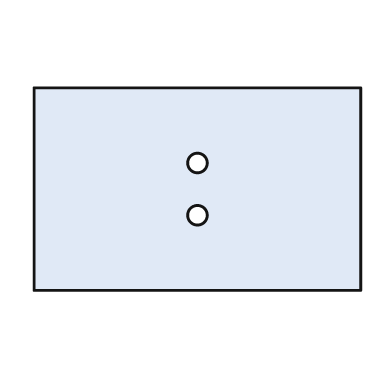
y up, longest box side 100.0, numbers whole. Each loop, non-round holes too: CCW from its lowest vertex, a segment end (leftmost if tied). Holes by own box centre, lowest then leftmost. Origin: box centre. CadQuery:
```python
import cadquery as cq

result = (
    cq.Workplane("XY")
    .moveTo(-50.0, -31.0)
    .lineTo(50.0, -31.0)
    .lineTo(50.0, 31.0)
    .lineTo(-50.0, 31.0)
    .close()
    .moveTo(0.0, -8.0)
    .circle(3.0)
    .moveTo(0.0, 8.0)
    .circle(3.0)
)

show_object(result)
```